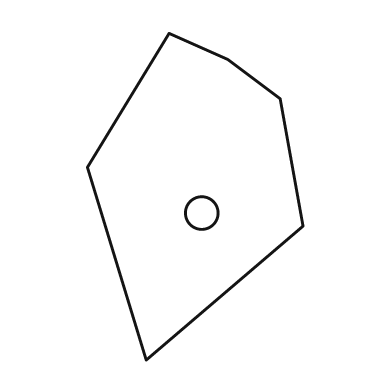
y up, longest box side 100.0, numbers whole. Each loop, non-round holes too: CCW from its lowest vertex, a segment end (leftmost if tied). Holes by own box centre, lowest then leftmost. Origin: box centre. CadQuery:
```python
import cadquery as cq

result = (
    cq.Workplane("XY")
    .moveTo(-15.0, -50.0)
    .lineTo(33.0, -9.0)
    .lineTo(26.0, 30.0)
    .lineTo(10.0, 42.0)
    .lineTo(-8.0, 50.0)
    .lineTo(-33.0, 9.0)
    .close()
    .moveTo(2.0, -5.0)
    .circle(5.0)
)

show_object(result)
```